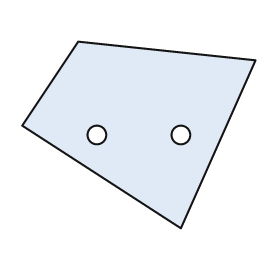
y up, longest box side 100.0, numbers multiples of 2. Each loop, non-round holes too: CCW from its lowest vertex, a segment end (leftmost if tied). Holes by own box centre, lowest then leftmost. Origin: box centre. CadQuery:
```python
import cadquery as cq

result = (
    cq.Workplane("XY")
    .moveTo(18.0, -40.0)
    .lineTo(50.0, 32.0)
    .lineTo(-26.0, 40.0)
    .lineTo(-50.0, 4.0)
    .close()
    .moveTo(-18.0, 0.0)
    .circle(4.0)
    .moveTo(18.0, 0.0)
    .circle(4.0)
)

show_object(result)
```